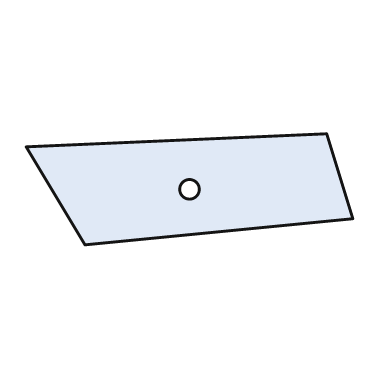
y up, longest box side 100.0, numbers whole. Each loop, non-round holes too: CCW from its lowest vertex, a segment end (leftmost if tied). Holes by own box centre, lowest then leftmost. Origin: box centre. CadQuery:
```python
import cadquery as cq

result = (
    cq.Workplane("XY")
    .moveTo(-32.0, -17.0)
    .lineTo(50.0, -9.0)
    .lineTo(42.0, 17.0)
    .lineTo(-50.0, 13.0)
    .close()
    .moveTo(0.0, 0.0)
    .circle(3.0)
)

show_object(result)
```